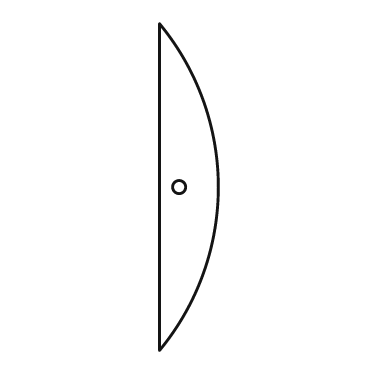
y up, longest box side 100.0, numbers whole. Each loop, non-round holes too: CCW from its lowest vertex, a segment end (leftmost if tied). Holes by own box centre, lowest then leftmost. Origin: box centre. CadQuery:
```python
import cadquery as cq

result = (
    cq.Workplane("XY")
    .moveTo(-9.0, -50.0)
    .threePointArc((9.0, 0.0), (-9.0, 50.0))
    .close()
    .moveTo(-3.0, 0.0)
    .circle(2.0)
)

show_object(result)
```